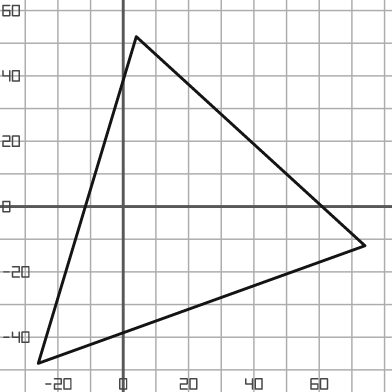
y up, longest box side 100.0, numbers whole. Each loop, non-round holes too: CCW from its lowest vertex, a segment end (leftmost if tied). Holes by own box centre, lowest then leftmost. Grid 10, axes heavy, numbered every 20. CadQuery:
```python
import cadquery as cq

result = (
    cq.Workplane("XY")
    .moveTo(-26.0, -48.0)
    .lineTo(74.0, -12.0)
    .lineTo(4.0, 52.0)
    .close()
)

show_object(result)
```